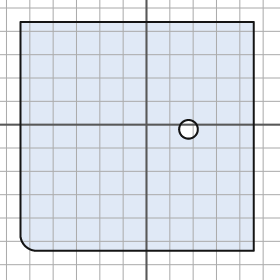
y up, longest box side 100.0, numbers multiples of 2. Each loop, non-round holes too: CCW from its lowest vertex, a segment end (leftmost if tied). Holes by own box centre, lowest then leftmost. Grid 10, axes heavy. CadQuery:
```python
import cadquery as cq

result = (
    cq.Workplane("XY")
    .moveTo(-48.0, -54.0)
    .lineTo(46.0, -54.0)
    .lineTo(46.0, 44.0)
    .lineTo(-54.0, 44.0)
    .lineTo(-54.0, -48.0)
    .threePointArc((-52.0, -52.0), (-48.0, -54.0))
    .close()
    .moveTo(18.0, -2.0)
    .circle(4.0)
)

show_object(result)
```